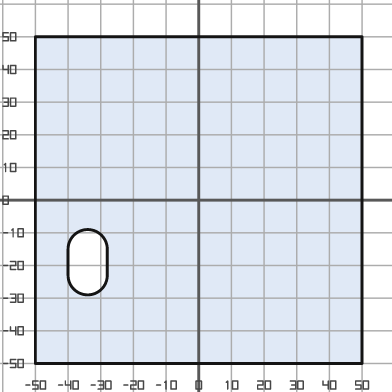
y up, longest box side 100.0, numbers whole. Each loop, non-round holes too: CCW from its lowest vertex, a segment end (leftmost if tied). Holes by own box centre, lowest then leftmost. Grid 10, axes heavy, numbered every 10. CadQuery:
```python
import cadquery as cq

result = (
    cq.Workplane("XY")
    .moveTo(-50.0, -50.0)
    .lineTo(50.0, -50.0)
    .lineTo(50.0, 50.0)
    .lineTo(-50.0, 50.0)
    .close()
    .moveTo(-40.0, -23.0)
    .threePointArc((-34.0, -29.0), (-28.0, -23.0))
    .lineTo(-28.0, -15.0)
    .threePointArc((-34.0, -9.0), (-40.0, -15.0))
    .close()
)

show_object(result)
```